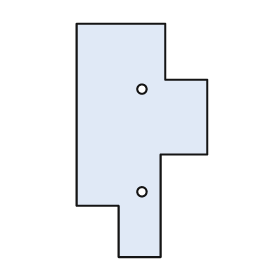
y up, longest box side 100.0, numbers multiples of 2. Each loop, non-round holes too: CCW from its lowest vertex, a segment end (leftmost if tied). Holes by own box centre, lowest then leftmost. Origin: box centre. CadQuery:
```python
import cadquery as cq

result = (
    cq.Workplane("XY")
    .moveTo(-10.0, -50.0)
    .lineTo(8.0, -50.0)
    .lineTo(8.0, -6.0)
    .lineTo(28.0, -6.0)
    .lineTo(28.0, 26.0)
    .lineTo(10.0, 26.0)
    .lineTo(10.0, 50.0)
    .lineTo(-28.0, 50.0)
    .lineTo(-28.0, -28.0)
    .lineTo(-10.0, -28.0)
    .close()
    .moveTo(0.0, -22.0)
    .circle(2.0)
    .moveTo(0.0, 22.0)
    .circle(2.0)
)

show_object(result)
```